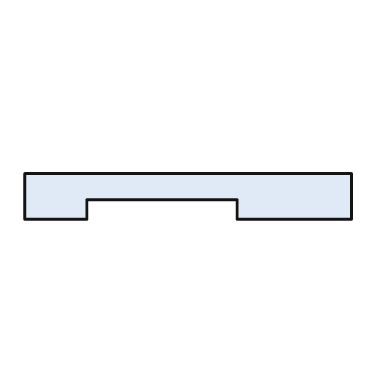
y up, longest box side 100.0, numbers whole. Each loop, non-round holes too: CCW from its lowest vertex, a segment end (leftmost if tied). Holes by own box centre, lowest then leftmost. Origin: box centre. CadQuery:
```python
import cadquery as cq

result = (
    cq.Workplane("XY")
    .moveTo(-50.0, -7.0)
    .lineTo(-31.0, -7.0)
    .lineTo(-31.0, -1.0)
    .lineTo(15.0, -1.0)
    .lineTo(15.0, -7.0)
    .lineTo(50.0, -7.0)
    .lineTo(50.0, 7.0)
    .lineTo(-50.0, 7.0)
    .close()
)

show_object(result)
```